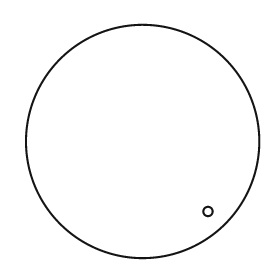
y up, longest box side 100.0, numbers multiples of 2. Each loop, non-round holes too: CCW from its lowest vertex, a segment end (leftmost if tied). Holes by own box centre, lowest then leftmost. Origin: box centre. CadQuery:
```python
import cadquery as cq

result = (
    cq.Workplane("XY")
    .moveTo(0.0, 0.0)
    .circle(50.0)
    .moveTo(28.0, -30.0)
    .circle(2.0)
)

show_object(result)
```